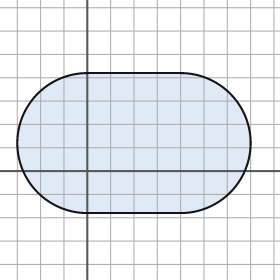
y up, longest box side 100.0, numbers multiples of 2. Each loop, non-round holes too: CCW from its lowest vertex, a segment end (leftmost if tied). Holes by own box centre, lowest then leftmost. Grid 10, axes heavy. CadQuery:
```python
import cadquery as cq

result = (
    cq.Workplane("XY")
    .moveTo(0.0, -18.0)
    .lineTo(40.0, -18.0)
    .threePointArc((70.0, 12.0), (40.0, 42.0))
    .lineTo(0.0, 42.0)
    .threePointArc((-30.0, 12.0), (0.0, -18.0))
    .close()
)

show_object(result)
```